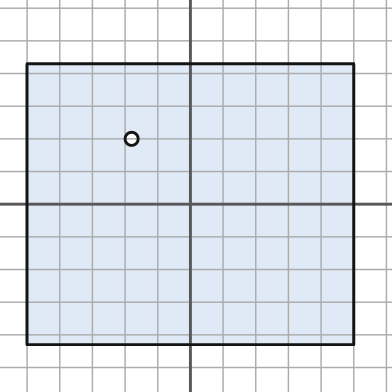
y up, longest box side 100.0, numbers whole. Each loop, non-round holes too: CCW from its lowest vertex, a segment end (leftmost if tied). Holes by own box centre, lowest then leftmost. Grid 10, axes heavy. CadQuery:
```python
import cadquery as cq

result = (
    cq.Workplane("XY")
    .moveTo(-50.0, -43.0)
    .lineTo(50.0, -43.0)
    .lineTo(50.0, 43.0)
    .lineTo(-50.0, 43.0)
    .close()
    .moveTo(-18.0, 20.0)
    .circle(2.0)
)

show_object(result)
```